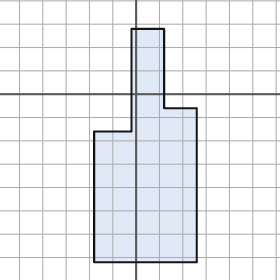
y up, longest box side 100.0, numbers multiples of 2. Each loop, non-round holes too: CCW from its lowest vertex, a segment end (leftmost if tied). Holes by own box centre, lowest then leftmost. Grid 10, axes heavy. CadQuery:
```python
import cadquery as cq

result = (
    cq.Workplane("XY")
    .moveTo(-18.0, -72.0)
    .lineTo(26.0, -72.0)
    .lineTo(26.0, -6.0)
    .lineTo(12.0, -6.0)
    .lineTo(12.0, 28.0)
    .lineTo(-2.0, 28.0)
    .lineTo(-2.0, -16.0)
    .lineTo(-18.0, -16.0)
    .close()
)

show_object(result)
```